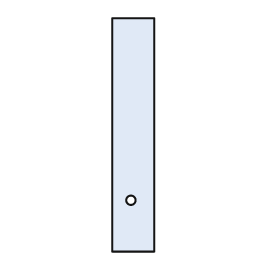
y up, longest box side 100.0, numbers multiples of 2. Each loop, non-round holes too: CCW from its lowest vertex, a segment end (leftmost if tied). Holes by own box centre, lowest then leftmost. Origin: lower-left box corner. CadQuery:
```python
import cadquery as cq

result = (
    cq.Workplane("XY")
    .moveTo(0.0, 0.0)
    .lineTo(18.0, 0.0)
    .lineTo(18.0, 100.0)
    .lineTo(0.0, 100.0)
    .close()
    .moveTo(8.0, 22.0)
    .circle(2.0)
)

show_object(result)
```